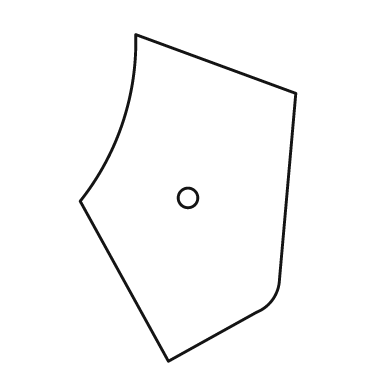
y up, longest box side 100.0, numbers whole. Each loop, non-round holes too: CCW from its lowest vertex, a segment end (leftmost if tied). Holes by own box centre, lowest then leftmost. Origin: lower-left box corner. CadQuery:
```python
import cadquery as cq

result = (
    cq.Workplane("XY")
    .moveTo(27.0, 0.0)
    .lineTo(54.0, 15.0)
    .threePointArc((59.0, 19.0), (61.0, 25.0))
    .lineTo(66.0, 82.0)
    .lineTo(17.0, 100.0)
    .threePointArc((13.0, 73.0), (0.0, 49.0))
    .close()
    .moveTo(33.0, 50.0)
    .circle(3.0)
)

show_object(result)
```